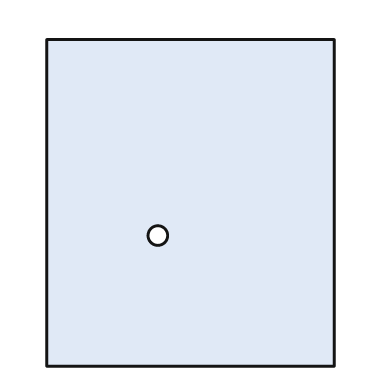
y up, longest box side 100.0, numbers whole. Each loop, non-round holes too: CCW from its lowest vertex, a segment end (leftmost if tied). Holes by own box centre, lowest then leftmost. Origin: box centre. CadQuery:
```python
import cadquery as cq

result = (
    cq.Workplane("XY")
    .moveTo(-44.0, -50.0)
    .lineTo(44.0, -50.0)
    .lineTo(44.0, 50.0)
    .lineTo(-44.0, 50.0)
    .close()
    .moveTo(-10.0, -10.0)
    .circle(3.0)
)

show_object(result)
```